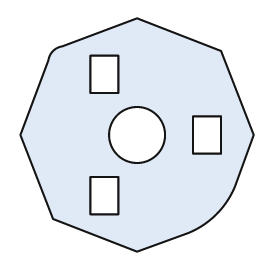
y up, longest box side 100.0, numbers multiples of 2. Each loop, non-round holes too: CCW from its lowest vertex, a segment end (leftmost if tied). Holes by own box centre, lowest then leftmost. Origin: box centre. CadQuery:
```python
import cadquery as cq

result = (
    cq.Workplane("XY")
    .moveTo(0.0, -50.0)
    .lineTo(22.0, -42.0)
    .threePointArc((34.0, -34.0), (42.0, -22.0))
    .lineTo(50.0, 0.0)
    .lineTo(36.0, 36.0)
    .lineTo(0.0, 50.0)
    .lineTo(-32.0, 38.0)
    .threePointArc((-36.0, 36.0), (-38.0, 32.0))
    .lineTo(-50.0, 0.0)
    .lineTo(-36.0, -36.0)
    .close()
    .moveTo(-20.0, -34.0)
    .lineTo(-8.0, -34.0)
    .lineTo(-8.0, -18.0)
    .lineTo(-20.0, -18.0)
    .close()
    .moveTo(0.0, 0.0)
    .circle(12.0)
    .moveTo(24.0, -8.0)
    .lineTo(36.0, -8.0)
    .lineTo(36.0, 8.0)
    .lineTo(24.0, 8.0)
    .close()
    .moveTo(-20.0, 18.0)
    .lineTo(-8.0, 18.0)
    .lineTo(-8.0, 34.0)
    .lineTo(-20.0, 34.0)
    .close()
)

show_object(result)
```